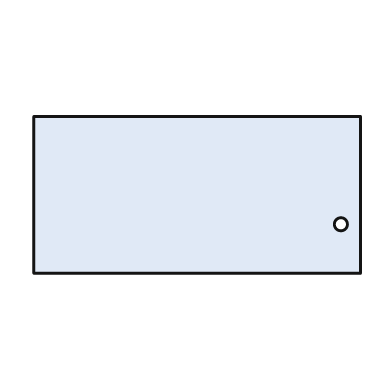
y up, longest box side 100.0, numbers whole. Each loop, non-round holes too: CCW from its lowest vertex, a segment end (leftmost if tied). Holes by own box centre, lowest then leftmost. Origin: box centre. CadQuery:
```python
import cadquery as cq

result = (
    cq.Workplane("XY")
    .moveTo(-50.0, -24.0)
    .lineTo(50.0, -24.0)
    .lineTo(50.0, 24.0)
    .lineTo(-50.0, 24.0)
    .close()
    .moveTo(44.0, -9.0)
    .circle(2.0)
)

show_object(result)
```